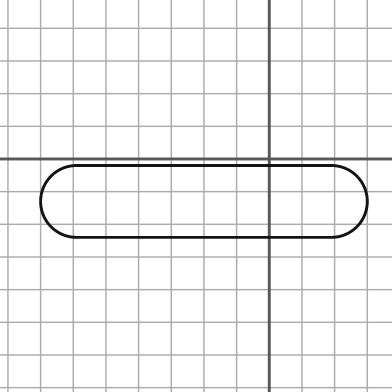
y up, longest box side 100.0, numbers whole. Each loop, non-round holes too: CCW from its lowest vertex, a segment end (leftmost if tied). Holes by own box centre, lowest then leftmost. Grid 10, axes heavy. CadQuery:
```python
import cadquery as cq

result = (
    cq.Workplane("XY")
    .moveTo(-59.0, -24.0)
    .lineTo(19.0, -24.0)
    .threePointArc((30.0, -13.0), (19.0, -2.0))
    .lineTo(-59.0, -2.0)
    .threePointArc((-70.0, -13.0), (-59.0, -24.0))
    .close()
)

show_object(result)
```